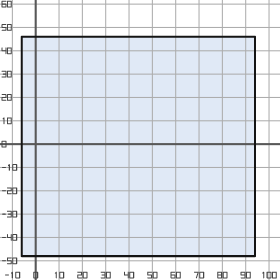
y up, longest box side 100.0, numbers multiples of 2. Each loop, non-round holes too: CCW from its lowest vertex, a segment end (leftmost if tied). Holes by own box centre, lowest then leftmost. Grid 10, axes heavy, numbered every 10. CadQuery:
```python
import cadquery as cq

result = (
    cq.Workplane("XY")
    .moveTo(-6.0, -48.0)
    .lineTo(94.0, -48.0)
    .lineTo(94.0, 46.0)
    .lineTo(-6.0, 46.0)
    .close()
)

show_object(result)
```